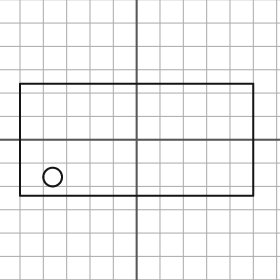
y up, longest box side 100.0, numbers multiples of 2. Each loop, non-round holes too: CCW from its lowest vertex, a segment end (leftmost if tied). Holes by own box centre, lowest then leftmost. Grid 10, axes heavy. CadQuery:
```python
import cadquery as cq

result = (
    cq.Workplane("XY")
    .moveTo(-50.0, -24.0)
    .lineTo(50.0, -24.0)
    .lineTo(50.0, 24.0)
    .lineTo(-50.0, 24.0)
    .close()
    .moveTo(-36.0, -16.0)
    .circle(4.0)
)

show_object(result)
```